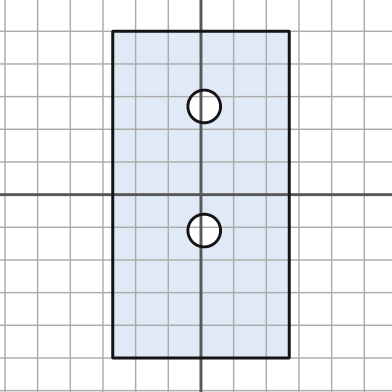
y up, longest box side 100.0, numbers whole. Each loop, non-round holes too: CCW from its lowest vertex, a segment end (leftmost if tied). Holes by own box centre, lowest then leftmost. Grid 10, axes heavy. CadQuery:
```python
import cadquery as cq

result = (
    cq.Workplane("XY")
    .moveTo(-27.0, -50.0)
    .lineTo(27.0, -50.0)
    .lineTo(27.0, 50.0)
    .lineTo(-27.0, 50.0)
    .close()
    .moveTo(1.0, -11.0)
    .circle(5.0)
    .moveTo(1.0, 27.0)
    .circle(5.0)
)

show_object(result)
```